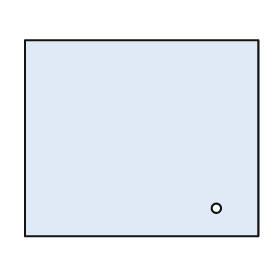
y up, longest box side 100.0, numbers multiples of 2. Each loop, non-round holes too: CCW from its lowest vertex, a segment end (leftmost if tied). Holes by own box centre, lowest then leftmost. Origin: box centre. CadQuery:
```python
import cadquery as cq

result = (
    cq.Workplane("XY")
    .moveTo(-50.0, -42.0)
    .lineTo(50.0, -42.0)
    .lineTo(50.0, 42.0)
    .lineTo(-50.0, 42.0)
    .close()
    .moveTo(32.0, -30.0)
    .circle(2.0)
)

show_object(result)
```